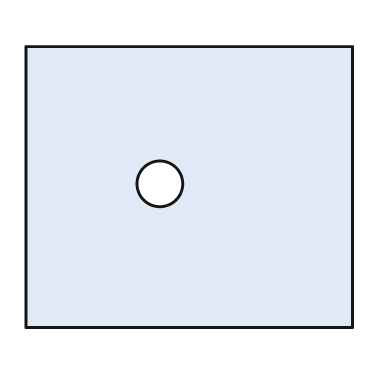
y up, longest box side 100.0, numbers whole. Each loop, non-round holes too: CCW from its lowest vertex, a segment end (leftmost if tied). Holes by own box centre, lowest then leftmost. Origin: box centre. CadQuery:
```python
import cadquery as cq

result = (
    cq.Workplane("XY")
    .moveTo(-50.0, -43.0)
    .lineTo(50.0, -43.0)
    .lineTo(50.0, 43.0)
    .lineTo(-50.0, 43.0)
    .close()
    .moveTo(-9.0, 1.0)
    .circle(7.0)
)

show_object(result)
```